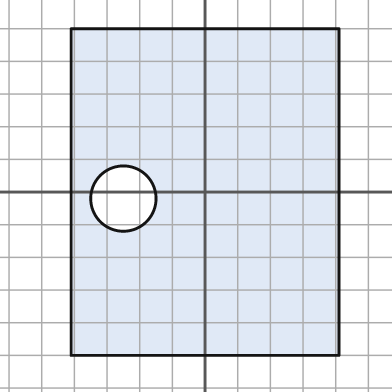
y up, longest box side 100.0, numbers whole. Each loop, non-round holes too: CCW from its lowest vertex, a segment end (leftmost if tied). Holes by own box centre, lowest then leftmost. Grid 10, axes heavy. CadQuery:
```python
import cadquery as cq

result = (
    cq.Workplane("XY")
    .moveTo(-41.0, -50.0)
    .lineTo(41.0, -50.0)
    .lineTo(41.0, 50.0)
    .lineTo(-41.0, 50.0)
    .close()
    .moveTo(-25.0, -2.0)
    .circle(10.0)
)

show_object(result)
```